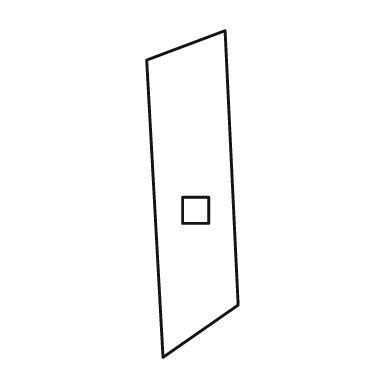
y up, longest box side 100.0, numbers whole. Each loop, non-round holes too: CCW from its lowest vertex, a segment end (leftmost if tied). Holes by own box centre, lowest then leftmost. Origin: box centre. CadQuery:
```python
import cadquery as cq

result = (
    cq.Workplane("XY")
    .moveTo(-9.0, -50.0)
    .lineTo(14.0, -34.0)
    .lineTo(10.0, 50.0)
    .lineTo(-14.0, 41.0)
    .close()
    .moveTo(-3.0, -9.0)
    .lineTo(5.0, -9.0)
    .lineTo(5.0, -1.0)
    .lineTo(-3.0, -1.0)
    .close()
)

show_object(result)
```